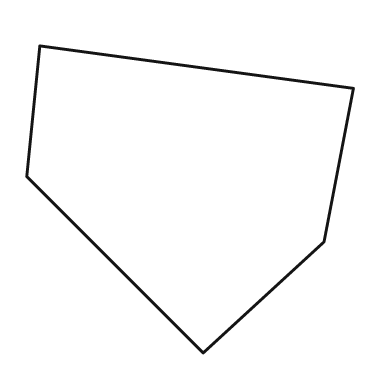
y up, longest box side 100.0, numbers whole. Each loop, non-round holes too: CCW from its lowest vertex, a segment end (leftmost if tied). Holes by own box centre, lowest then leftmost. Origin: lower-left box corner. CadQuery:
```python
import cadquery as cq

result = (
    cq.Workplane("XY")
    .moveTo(54.0, 0.0)
    .lineTo(91.0, 34.0)
    .lineTo(100.0, 81.0)
    .lineTo(4.0, 94.0)
    .lineTo(0.0, 54.0)
    .close()
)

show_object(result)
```